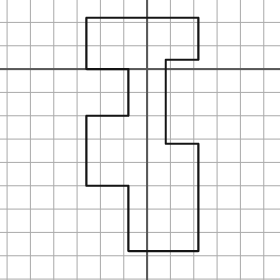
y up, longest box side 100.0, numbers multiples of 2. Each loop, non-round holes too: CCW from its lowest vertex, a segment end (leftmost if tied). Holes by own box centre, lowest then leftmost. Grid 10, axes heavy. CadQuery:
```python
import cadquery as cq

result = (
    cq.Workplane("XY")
    .moveTo(-8.0, -78.0)
    .lineTo(22.0, -78.0)
    .lineTo(22.0, -32.0)
    .lineTo(8.0, -32.0)
    .lineTo(8.0, 4.0)
    .lineTo(22.0, 4.0)
    .lineTo(22.0, 22.0)
    .lineTo(-26.0, 22.0)
    .lineTo(-26.0, 0.0)
    .lineTo(-8.0, 0.0)
    .lineTo(-8.0, -20.0)
    .lineTo(-26.0, -20.0)
    .lineTo(-26.0, -50.0)
    .lineTo(-8.0, -50.0)
    .close()
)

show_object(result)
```